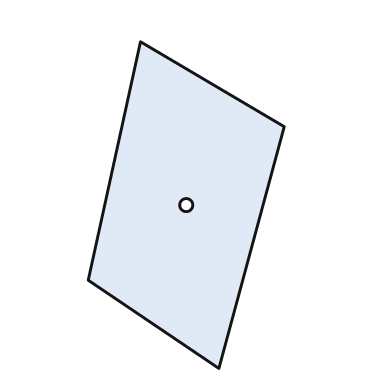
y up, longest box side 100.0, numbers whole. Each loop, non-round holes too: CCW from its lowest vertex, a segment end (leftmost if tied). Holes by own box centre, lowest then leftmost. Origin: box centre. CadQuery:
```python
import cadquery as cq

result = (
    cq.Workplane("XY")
    .moveTo(10.0, -50.0)
    .lineTo(30.0, 24.0)
    .lineTo(-14.0, 50.0)
    .lineTo(-30.0, -23.0)
    .close()
    .moveTo(0.0, 0.0)
    .circle(2.0)
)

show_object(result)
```